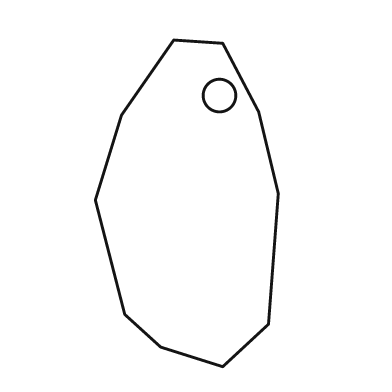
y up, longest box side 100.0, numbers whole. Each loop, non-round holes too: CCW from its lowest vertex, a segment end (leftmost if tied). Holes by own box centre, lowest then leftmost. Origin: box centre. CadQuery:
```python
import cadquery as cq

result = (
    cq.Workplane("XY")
    .moveTo(11.0, -50.0)
    .lineTo(25.0, -37.0)
    .lineTo(28.0, 3.0)
    .lineTo(22.0, 28.0)
    .lineTo(11.0, 49.0)
    .lineTo(-4.0, 50.0)
    .lineTo(-20.0, 27.0)
    .lineTo(-28.0, 1.0)
    .lineTo(-19.0, -34.0)
    .lineTo(-8.0, -44.0)
    .close()
    .moveTo(10.0, 33.0)
    .circle(5.0)
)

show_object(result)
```